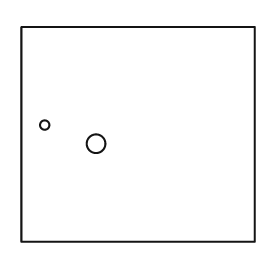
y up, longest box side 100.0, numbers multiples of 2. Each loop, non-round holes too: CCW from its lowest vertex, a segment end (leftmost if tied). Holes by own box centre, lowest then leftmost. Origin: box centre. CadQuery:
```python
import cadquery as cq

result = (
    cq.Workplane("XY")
    .moveTo(-50.0, -46.0)
    .lineTo(50.0, -46.0)
    .lineTo(50.0, 46.0)
    .lineTo(-50.0, 46.0)
    .close()
    .moveTo(-18.0, -4.0)
    .circle(4.0)
    .moveTo(-40.0, 4.0)
    .circle(2.0)
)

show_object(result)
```